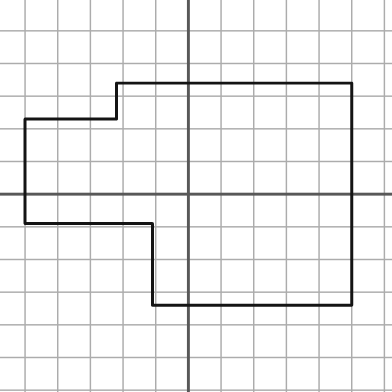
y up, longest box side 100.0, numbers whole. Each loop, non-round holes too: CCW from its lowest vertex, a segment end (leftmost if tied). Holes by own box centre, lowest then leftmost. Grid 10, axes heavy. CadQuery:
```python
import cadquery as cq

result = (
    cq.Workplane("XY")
    .moveTo(-11.0, -34.0)
    .lineTo(50.0, -34.0)
    .lineTo(50.0, 34.0)
    .lineTo(-22.0, 34.0)
    .lineTo(-22.0, 23.0)
    .lineTo(-50.0, 23.0)
    .lineTo(-50.0, -9.0)
    .lineTo(-11.0, -9.0)
    .close()
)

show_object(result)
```